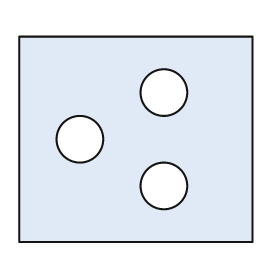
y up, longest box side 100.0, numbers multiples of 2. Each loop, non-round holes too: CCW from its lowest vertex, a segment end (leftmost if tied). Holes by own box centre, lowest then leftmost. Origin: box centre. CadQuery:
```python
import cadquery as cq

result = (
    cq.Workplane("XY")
    .moveTo(-50.0, -44.0)
    .lineTo(50.0, -44.0)
    .lineTo(50.0, 44.0)
    .lineTo(-50.0, 44.0)
    .close()
    .moveTo(12.0, -20.0)
    .circle(10.0)
    .moveTo(-24.0, 0.0)
    .circle(10.0)
    .moveTo(12.0, 20.0)
    .circle(10.0)
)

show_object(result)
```